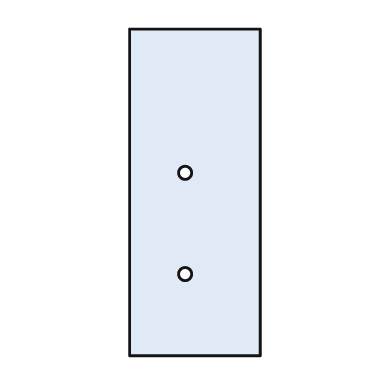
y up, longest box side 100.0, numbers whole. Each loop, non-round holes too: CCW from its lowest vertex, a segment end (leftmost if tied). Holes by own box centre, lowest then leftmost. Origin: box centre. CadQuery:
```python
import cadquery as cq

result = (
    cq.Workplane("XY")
    .moveTo(-20.0, -50.0)
    .lineTo(20.0, -50.0)
    .lineTo(20.0, 50.0)
    .lineTo(-20.0, 50.0)
    .close()
    .moveTo(-3.0, -25.0)
    .circle(2.0)
    .moveTo(-3.0, 6.0)
    .circle(2.0)
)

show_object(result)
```